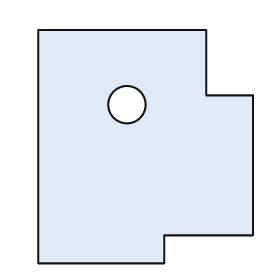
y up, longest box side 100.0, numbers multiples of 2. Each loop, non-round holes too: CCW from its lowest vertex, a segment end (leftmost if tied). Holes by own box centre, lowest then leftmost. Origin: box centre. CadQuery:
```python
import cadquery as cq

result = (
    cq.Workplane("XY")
    .moveTo(-46.0, -50.0)
    .lineTo(8.0, -50.0)
    .lineTo(8.0, -38.0)
    .lineTo(46.0, -38.0)
    .lineTo(46.0, 22.0)
    .lineTo(26.0, 22.0)
    .lineTo(26.0, 50.0)
    .lineTo(-46.0, 50.0)
    .close()
    .moveTo(-8.0, 18.0)
    .circle(8.0)
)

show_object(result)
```